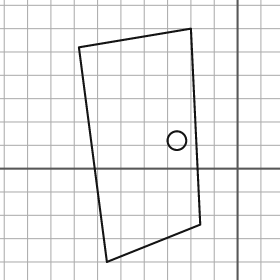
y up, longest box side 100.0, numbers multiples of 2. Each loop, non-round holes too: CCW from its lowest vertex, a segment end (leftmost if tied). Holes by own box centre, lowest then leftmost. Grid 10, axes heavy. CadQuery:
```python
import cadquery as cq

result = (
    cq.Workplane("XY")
    .moveTo(-56.0, -40.0)
    .lineTo(-16.0, -24.0)
    .lineTo(-20.0, 60.0)
    .lineTo(-68.0, 52.0)
    .close()
    .moveTo(-26.0, 12.0)
    .circle(4.0)
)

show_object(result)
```